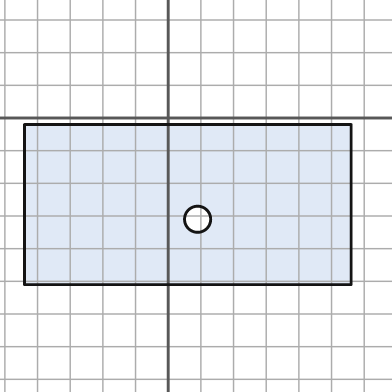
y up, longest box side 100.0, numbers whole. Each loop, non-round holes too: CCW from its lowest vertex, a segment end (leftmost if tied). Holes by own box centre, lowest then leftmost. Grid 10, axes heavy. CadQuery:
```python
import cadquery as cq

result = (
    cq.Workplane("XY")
    .moveTo(-44.0, -51.0)
    .lineTo(56.0, -51.0)
    .lineTo(56.0, -2.0)
    .lineTo(-44.0, -2.0)
    .close()
    .moveTo(9.0, -31.0)
    .circle(4.0)
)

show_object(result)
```